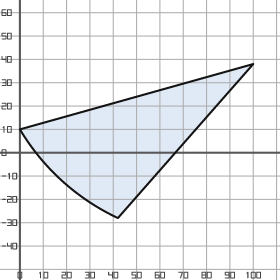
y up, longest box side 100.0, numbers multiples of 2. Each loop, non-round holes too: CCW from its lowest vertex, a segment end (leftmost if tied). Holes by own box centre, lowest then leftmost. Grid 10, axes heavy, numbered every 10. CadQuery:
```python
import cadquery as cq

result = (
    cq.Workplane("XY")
    .moveTo(42.0, -28.0)
    .lineTo(100.0, 38.0)
    .lineTo(0.0, 10.0)
    .threePointArc((18.0, -12.0), (42.0, -28.0))
    .close()
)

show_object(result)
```